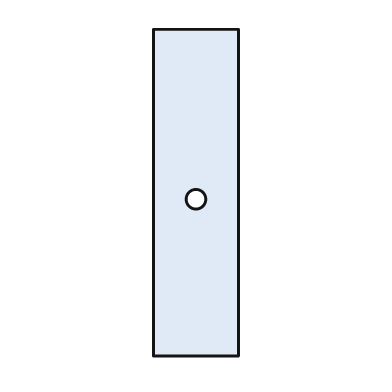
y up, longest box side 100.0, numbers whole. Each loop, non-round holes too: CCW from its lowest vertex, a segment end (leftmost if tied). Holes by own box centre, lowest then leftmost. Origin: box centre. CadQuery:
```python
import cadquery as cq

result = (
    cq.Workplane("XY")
    .moveTo(-13.0, -50.0)
    .lineTo(13.0, -50.0)
    .lineTo(13.0, 50.0)
    .lineTo(-13.0, 50.0)
    .close()
    .moveTo(0.0, -2.0)
    .circle(3.0)
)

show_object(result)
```